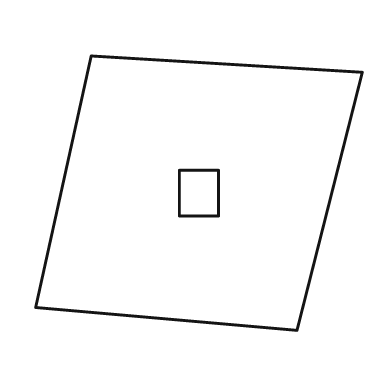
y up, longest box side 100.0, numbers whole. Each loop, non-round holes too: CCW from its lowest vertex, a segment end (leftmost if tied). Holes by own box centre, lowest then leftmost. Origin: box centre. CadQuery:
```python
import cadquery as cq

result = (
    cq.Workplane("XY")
    .moveTo(30.0, -42.0)
    .lineTo(50.0, 37.0)
    .lineTo(-33.0, 42.0)
    .lineTo(-50.0, -35.0)
    .close()
    .moveTo(-6.0, -7.0)
    .lineTo(6.0, -7.0)
    .lineTo(6.0, 7.0)
    .lineTo(-6.0, 7.0)
    .close()
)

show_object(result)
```